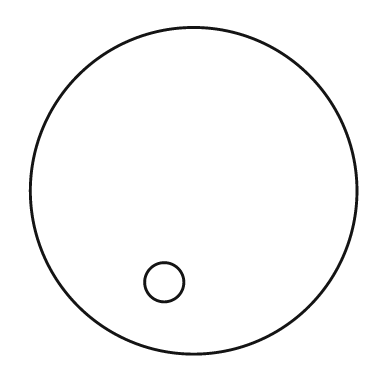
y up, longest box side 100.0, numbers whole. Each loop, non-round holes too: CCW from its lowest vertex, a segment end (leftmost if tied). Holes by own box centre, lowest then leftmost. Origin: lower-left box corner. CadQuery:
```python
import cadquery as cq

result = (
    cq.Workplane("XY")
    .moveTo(50.0, 50.0)
    .circle(50.0)
    .moveTo(41.0, 22.0)
    .circle(6.0)
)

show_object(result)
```